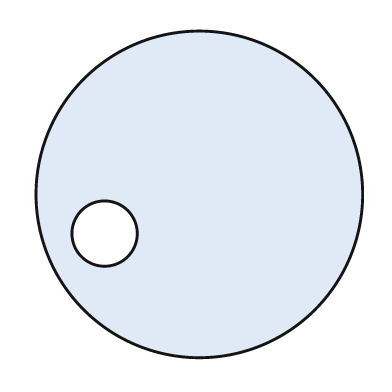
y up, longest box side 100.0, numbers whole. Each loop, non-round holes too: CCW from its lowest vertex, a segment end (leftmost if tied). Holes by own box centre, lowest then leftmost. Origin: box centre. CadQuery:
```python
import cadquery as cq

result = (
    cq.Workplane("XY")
    .moveTo(0.0, 0.0)
    .circle(50.0)
    .moveTo(-29.0, -12.0)
    .circle(10.0)
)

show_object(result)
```